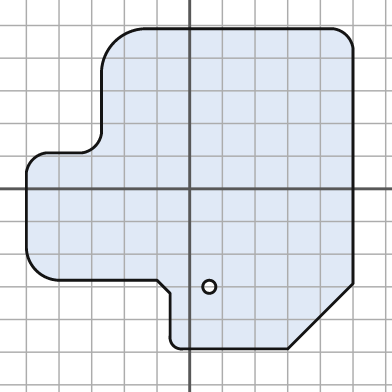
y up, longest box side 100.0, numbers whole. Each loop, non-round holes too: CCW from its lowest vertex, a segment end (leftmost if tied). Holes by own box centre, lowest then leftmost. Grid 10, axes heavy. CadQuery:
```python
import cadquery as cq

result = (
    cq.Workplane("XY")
    .moveTo(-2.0, -49.0)
    .lineTo(30.0, -49.0)
    .lineTo(50.0, -29.0)
    .lineTo(50.0, 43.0)
    .threePointArc((48.0, 47.0), (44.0, 49.0))
    .lineTo(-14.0, 49.0)
    .threePointArc((-23.0, 45.0), (-27.0, 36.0))
    .lineTo(-27.0, 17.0)
    .threePointArc((-29.0, 13.0), (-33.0, 11.0))
    .lineTo(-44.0, 11.0)
    .threePointArc((-48.0, 9.0), (-50.0, 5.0))
    .lineTo(-50.0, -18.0)
    .threePointArc((-47.0, -25.0), (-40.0, -28.0))
    .lineTo(-10.0, -28.0)
    .lineTo(-6.0, -32.0)
    .lineTo(-6.0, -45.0)
    .threePointArc((-5.0, -48.0), (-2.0, -49.0))
    .close()
    .moveTo(6.0, -30.0)
    .circle(2.0)
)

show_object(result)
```